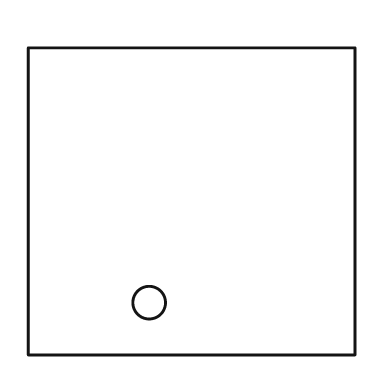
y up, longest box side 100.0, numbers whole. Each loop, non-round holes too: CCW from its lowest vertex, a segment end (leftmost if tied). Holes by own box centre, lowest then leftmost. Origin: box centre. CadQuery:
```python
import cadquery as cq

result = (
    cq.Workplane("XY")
    .moveTo(-50.0, -47.0)
    .lineTo(50.0, -47.0)
    .lineTo(50.0, 47.0)
    .lineTo(-50.0, 47.0)
    .close()
    .moveTo(-13.0, -31.0)
    .circle(5.0)
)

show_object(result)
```